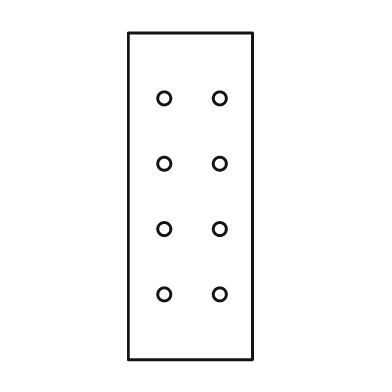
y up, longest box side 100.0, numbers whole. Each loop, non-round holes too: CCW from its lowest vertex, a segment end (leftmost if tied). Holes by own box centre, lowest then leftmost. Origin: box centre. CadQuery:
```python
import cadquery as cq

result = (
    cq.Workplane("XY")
    .moveTo(-19.0, -50.0)
    .lineTo(19.0, -50.0)
    .lineTo(19.0, 50.0)
    .lineTo(-19.0, 50.0)
    .close()
    .moveTo(-8.0, -30.0)
    .circle(2.0)
    .moveTo(9.0, -30.0)
    .circle(2.0)
    .moveTo(-8.0, -10.0)
    .circle(2.0)
    .moveTo(9.0, -10.0)
    .circle(2.0)
    .moveTo(-8.0, 10.0)
    .circle(2.0)
    .moveTo(9.0, 10.0)
    .circle(2.0)
    .moveTo(-8.0, 30.0)
    .circle(2.0)
    .moveTo(9.0, 30.0)
    .circle(2.0)
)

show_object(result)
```